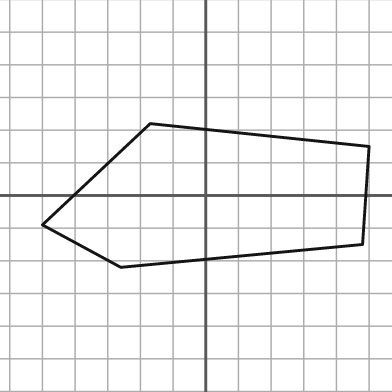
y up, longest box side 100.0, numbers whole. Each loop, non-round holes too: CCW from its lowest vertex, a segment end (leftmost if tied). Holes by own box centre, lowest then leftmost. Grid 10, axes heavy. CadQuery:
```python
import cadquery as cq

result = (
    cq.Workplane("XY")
    .moveTo(-26.0, -22.0)
    .lineTo(48.0, -15.0)
    .lineTo(50.0, 15.0)
    .lineTo(-17.0, 22.0)
    .lineTo(-50.0, -9.0)
    .close()
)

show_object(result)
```